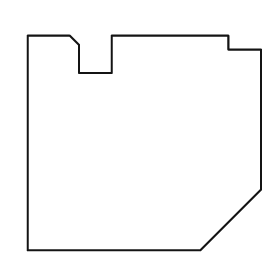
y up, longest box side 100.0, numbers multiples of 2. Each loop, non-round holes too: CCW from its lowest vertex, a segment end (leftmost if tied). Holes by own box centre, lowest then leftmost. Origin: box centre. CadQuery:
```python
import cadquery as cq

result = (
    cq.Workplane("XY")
    .moveTo(-50.0, -46.0)
    .lineTo(24.0, -46.0)
    .lineTo(50.0, -20.0)
    .lineTo(50.0, 40.0)
    .lineTo(36.0, 40.0)
    .lineTo(36.0, 46.0)
    .lineTo(-14.0, 46.0)
    .lineTo(-14.0, 30.0)
    .lineTo(-28.0, 30.0)
    .lineTo(-28.0, 42.0)
    .lineTo(-32.0, 46.0)
    .lineTo(-50.0, 46.0)
    .close()
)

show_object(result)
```